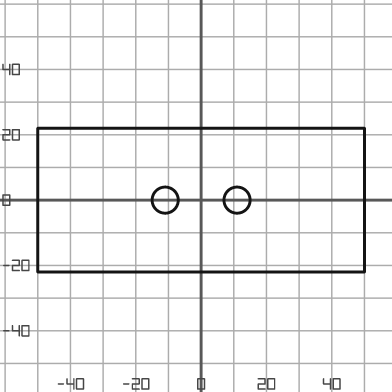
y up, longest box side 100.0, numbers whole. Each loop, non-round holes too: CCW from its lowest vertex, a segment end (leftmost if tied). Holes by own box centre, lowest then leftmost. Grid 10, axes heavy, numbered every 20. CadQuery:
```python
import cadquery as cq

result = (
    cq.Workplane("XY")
    .moveTo(-50.0, -22.0)
    .lineTo(50.0, -22.0)
    .lineTo(50.0, 22.0)
    .lineTo(-50.0, 22.0)
    .close()
    .moveTo(-11.0, 0.0)
    .circle(4.0)
    .moveTo(11.0, 0.0)
    .circle(4.0)
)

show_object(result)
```